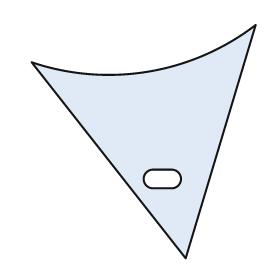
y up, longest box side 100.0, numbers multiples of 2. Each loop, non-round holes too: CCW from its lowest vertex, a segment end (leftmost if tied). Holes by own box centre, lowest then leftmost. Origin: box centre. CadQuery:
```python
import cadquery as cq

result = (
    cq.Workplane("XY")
    .moveTo(18.0, -50.0)
    .lineTo(48.0, 50.0)
    .threePointArc((2.0, 30.0), (-48.0, 34.0))
    .close()
    .moveTo(4.0, -20.0)
    .lineTo(12.0, -20.0)
    .threePointArc((16.0, -16.0), (12.0, -12.0))
    .lineTo(4.0, -12.0)
    .threePointArc((0.0, -16.0), (4.0, -20.0))
    .close()
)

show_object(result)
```